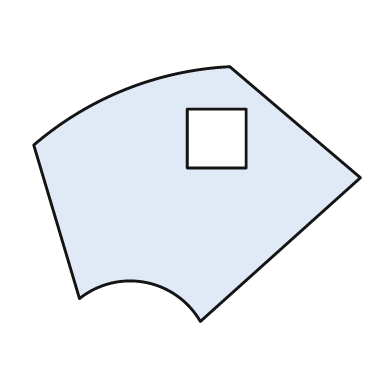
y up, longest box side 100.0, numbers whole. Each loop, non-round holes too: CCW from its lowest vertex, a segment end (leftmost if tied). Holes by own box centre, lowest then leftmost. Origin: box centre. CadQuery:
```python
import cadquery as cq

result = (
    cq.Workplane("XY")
    .moveTo(1.0, -39.0)
    .lineTo(50.0, 5.0)
    .lineTo(10.0, 39.0)
    .threePointArc((-22.0, 32.0), (-50.0, 15.0))
    .lineTo(-36.0, -32.0)
    .threePointArc((-16.0, -27.0), (1.0, -39.0))
    .close()
    .moveTo(-3.0, 8.0)
    .lineTo(15.0, 8.0)
    .lineTo(15.0, 26.0)
    .lineTo(-3.0, 26.0)
    .close()
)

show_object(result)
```